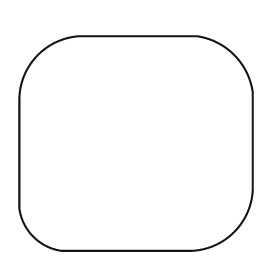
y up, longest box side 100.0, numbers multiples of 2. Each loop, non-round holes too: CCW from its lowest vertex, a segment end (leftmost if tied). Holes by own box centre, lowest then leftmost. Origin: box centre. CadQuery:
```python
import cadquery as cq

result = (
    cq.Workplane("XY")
    .moveTo(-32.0, -46.0)
    .lineTo(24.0, -46.0)
    .threePointArc((42.0, -38.0), (50.0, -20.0))
    .lineTo(50.0, 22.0)
    .threePointArc((42.0, 38.0), (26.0, 46.0))
    .lineTo(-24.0, 46.0)
    .threePointArc((-42.0, 38.0), (-50.0, 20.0))
    .lineTo(-50.0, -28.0)
    .threePointArc((-44.0, -40.0), (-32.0, -46.0))
    .close()
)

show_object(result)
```